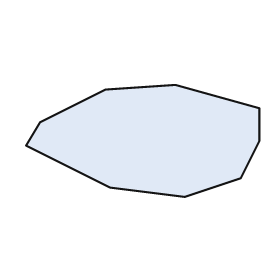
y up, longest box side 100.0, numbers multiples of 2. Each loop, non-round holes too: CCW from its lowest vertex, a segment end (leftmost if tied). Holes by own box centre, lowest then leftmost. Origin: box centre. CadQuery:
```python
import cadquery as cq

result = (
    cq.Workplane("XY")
    .moveTo(18.0, -24.0)
    .lineTo(42.0, -16.0)
    .lineTo(50.0, 0.0)
    .lineTo(50.0, 14.0)
    .lineTo(14.0, 24.0)
    .lineTo(-16.0, 22.0)
    .lineTo(-44.0, 8.0)
    .lineTo(-50.0, -2.0)
    .lineTo(-14.0, -20.0)
    .close()
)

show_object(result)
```